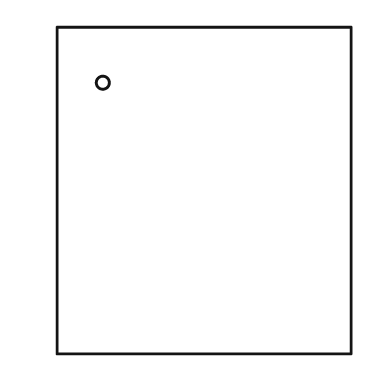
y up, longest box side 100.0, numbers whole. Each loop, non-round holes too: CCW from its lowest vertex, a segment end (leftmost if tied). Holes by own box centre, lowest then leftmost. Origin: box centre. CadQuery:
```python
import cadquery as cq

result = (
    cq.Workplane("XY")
    .moveTo(-45.0, -50.0)
    .lineTo(45.0, -50.0)
    .lineTo(45.0, 50.0)
    .lineTo(-45.0, 50.0)
    .close()
    .moveTo(-31.0, 33.0)
    .circle(2.0)
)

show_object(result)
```